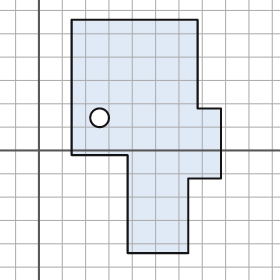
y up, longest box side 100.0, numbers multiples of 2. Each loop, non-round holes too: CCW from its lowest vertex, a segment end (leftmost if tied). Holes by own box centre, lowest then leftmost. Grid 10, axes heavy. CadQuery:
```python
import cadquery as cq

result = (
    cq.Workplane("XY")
    .moveTo(38.0, -44.0)
    .lineTo(64.0, -44.0)
    .lineTo(64.0, -12.0)
    .lineTo(78.0, -12.0)
    .lineTo(78.0, 18.0)
    .lineTo(68.0, 18.0)
    .lineTo(68.0, 56.0)
    .lineTo(14.0, 56.0)
    .lineTo(14.0, -2.0)
    .lineTo(38.0, -2.0)
    .close()
    .moveTo(26.0, 14.0)
    .circle(4.0)
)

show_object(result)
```